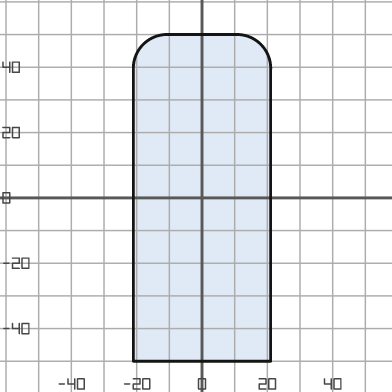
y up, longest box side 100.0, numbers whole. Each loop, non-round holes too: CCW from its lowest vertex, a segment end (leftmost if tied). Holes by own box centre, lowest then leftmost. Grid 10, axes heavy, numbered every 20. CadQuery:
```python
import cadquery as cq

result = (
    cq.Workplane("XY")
    .moveTo(-21.0, -50.0)
    .lineTo(21.0, -50.0)
    .lineTo(21.0, 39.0)
    .threePointArc((18.0, 47.0), (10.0, 50.0))
    .lineTo(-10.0, 50.0)
    .threePointArc((-18.0, 47.0), (-21.0, 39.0))
    .close()
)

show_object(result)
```